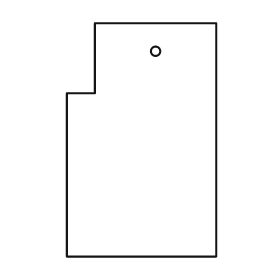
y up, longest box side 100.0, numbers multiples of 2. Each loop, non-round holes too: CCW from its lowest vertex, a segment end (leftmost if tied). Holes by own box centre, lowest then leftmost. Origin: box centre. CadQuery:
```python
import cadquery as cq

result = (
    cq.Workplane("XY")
    .moveTo(-32.0, -50.0)
    .lineTo(32.0, -50.0)
    .lineTo(32.0, 50.0)
    .lineTo(-20.0, 50.0)
    .lineTo(-20.0, 20.0)
    .lineTo(-32.0, 20.0)
    .close()
    .moveTo(6.0, 38.0)
    .circle(2.0)
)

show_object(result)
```